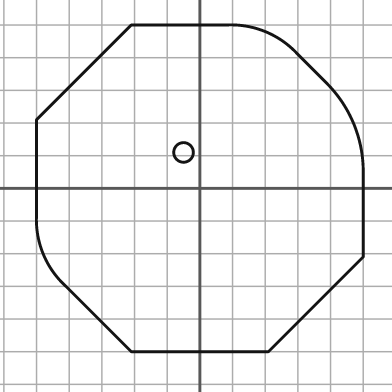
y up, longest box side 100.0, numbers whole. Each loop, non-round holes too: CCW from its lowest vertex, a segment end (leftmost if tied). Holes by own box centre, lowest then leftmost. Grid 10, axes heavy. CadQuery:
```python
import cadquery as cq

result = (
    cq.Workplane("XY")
    .moveTo(-21.0, -50.0)
    .lineTo(21.0, -50.0)
    .lineTo(50.0, -21.0)
    .lineTo(50.0, 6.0)
    .threePointArc((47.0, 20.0), (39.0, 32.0))
    .lineTo(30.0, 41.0)
    .threePointArc((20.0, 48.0), (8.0, 50.0))
    .lineTo(-21.0, 50.0)
    .lineTo(-50.0, 21.0)
    .lineTo(-50.0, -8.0)
    .threePointArc((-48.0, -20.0), (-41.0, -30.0))
    .close()
    .moveTo(-5.0, 11.0)
    .circle(3.0)
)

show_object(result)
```